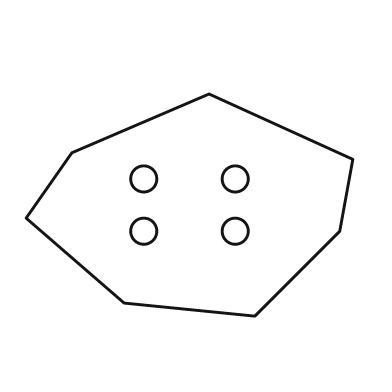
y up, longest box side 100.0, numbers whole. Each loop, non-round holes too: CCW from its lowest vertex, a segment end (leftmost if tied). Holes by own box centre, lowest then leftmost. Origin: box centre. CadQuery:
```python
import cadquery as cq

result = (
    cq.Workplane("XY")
    .moveTo(20.0, -34.0)
    .lineTo(46.0, -8.0)
    .lineTo(50.0, 14.0)
    .lineTo(6.0, 34.0)
    .lineTo(-36.0, 16.0)
    .lineTo(-50.0, -4.0)
    .lineTo(-20.0, -30.0)
    .close()
    .moveTo(-14.0, -8.0)
    .circle(4.0)
    .moveTo(14.0, -8.0)
    .circle(4.0)
    .moveTo(-14.0, 8.0)
    .circle(4.0)
    .moveTo(14.0, 8.0)
    .circle(4.0)
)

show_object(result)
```